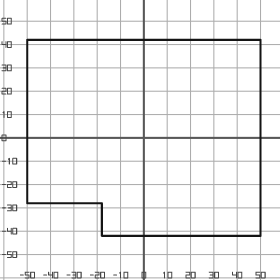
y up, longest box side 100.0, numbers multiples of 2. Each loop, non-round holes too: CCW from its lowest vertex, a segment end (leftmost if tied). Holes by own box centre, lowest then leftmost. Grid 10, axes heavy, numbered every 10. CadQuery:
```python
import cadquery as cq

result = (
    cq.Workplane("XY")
    .moveTo(-18.0, -42.0)
    .lineTo(50.0, -42.0)
    .lineTo(50.0, 42.0)
    .lineTo(-50.0, 42.0)
    .lineTo(-50.0, -28.0)
    .lineTo(-18.0, -28.0)
    .close()
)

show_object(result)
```